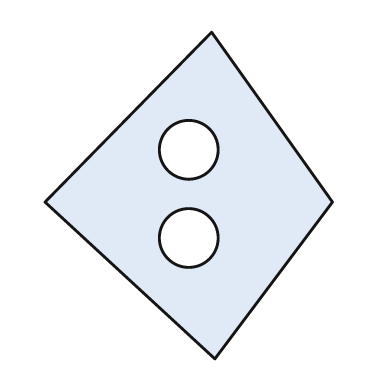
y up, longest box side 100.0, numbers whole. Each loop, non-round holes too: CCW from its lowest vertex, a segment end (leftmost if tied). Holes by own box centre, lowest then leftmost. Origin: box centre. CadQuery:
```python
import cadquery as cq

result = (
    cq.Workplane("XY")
    .moveTo(8.0, -50.0)
    .lineTo(44.0, -2.0)
    .lineTo(7.0, 50.0)
    .lineTo(-44.0, -2.0)
    .close()
    .moveTo(0.0, -13.0)
    .circle(9.0)
    .moveTo(0.0, 14.0)
    .circle(9.0)
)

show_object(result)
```